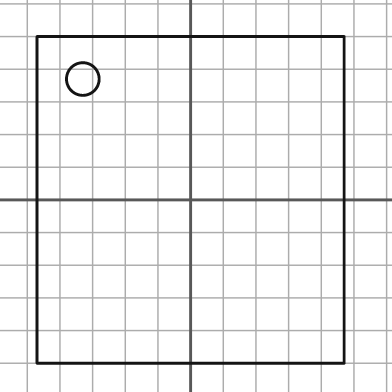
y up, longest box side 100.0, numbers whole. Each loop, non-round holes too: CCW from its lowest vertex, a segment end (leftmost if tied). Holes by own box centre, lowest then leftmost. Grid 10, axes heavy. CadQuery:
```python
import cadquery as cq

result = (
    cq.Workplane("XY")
    .moveTo(-47.0, -50.0)
    .lineTo(47.0, -50.0)
    .lineTo(47.0, 50.0)
    .lineTo(-47.0, 50.0)
    .close()
    .moveTo(-33.0, 37.0)
    .circle(5.0)
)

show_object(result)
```